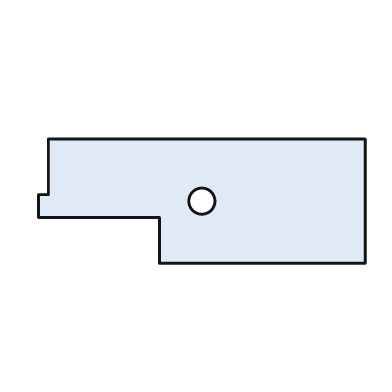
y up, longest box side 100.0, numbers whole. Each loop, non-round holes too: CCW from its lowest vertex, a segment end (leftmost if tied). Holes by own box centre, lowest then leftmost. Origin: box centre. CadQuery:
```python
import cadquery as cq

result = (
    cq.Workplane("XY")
    .moveTo(-13.0, -19.0)
    .lineTo(50.0, -19.0)
    .lineTo(50.0, 19.0)
    .lineTo(-47.0, 19.0)
    .lineTo(-47.0, 2.0)
    .lineTo(-50.0, 2.0)
    .lineTo(-50.0, -5.0)
    .lineTo(-13.0, -5.0)
    .close()
    .moveTo(0.0, 0.0)
    .circle(4.0)
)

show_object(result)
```